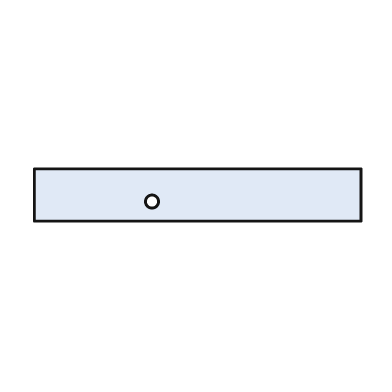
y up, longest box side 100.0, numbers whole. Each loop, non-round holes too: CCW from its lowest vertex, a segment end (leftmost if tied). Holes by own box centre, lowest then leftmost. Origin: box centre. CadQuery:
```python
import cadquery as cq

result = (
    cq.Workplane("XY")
    .moveTo(-50.0, -8.0)
    .lineTo(50.0, -8.0)
    .lineTo(50.0, 8.0)
    .lineTo(-50.0, 8.0)
    .close()
    .moveTo(-14.0, -2.0)
    .circle(2.0)
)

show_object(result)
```